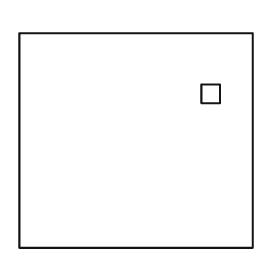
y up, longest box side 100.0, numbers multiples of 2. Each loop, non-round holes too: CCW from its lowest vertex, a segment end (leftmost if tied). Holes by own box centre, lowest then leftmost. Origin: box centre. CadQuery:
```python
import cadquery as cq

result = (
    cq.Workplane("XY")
    .moveTo(-50.0, -46.0)
    .lineTo(50.0, -46.0)
    .lineTo(50.0, 46.0)
    .lineTo(-50.0, 46.0)
    .close()
    .moveTo(28.0, 16.0)
    .lineTo(36.0, 16.0)
    .lineTo(36.0, 24.0)
    .lineTo(28.0, 24.0)
    .close()
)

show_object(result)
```